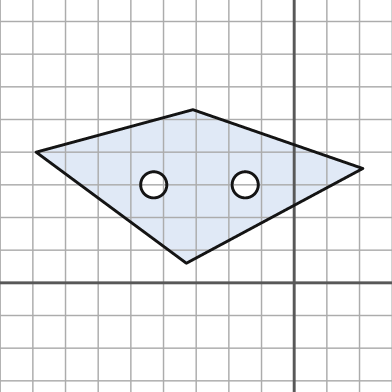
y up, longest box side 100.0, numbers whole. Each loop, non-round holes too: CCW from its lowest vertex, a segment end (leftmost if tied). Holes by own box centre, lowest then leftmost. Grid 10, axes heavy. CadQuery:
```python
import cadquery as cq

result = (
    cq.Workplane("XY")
    .moveTo(-33.0, 6.0)
    .lineTo(21.0, 35.0)
    .lineTo(-31.0, 53.0)
    .lineTo(-79.0, 40.0)
    .close()
    .moveTo(-43.0, 30.0)
    .circle(4.0)
    .moveTo(-15.0, 30.0)
    .circle(4.0)
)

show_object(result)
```